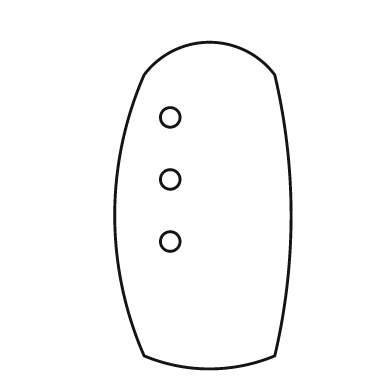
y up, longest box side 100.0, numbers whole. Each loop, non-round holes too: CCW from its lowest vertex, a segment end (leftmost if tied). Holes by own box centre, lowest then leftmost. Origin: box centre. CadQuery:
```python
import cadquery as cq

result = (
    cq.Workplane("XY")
    .moveTo(-18.0, -46.0)
    .threePointArc((2.0, -50.0), (22.0, -46.0))
    .threePointArc((27.0, -3.0), (22.0, 40.0))
    .threePointArc((2.0, 50.0), (-18.0, 40.0))
    .threePointArc((-27.0, -3.0), (-18.0, -46.0))
    .close()
    .moveTo(-10.0, -11.0)
    .circle(3.0)
    .moveTo(-10.0, 8.0)
    .circle(3.0)
    .moveTo(-10.0, 27.0)
    .circle(3.0)
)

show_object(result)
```